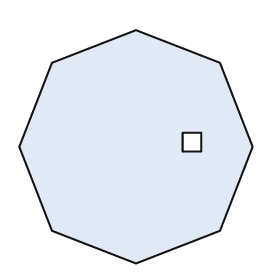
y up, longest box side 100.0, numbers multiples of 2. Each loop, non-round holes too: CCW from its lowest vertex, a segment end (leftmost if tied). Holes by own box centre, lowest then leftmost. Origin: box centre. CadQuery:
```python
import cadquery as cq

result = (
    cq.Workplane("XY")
    .moveTo(0.0, -50.0)
    .lineTo(36.0, -36.0)
    .lineTo(50.0, 0.0)
    .lineTo(36.0, 36.0)
    .lineTo(0.0, 50.0)
    .lineTo(-36.0, 36.0)
    .lineTo(-50.0, 0.0)
    .lineTo(-36.0, -36.0)
    .close()
    .moveTo(20.0, -2.0)
    .lineTo(28.0, -2.0)
    .lineTo(28.0, 6.0)
    .lineTo(20.0, 6.0)
    .close()
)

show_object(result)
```